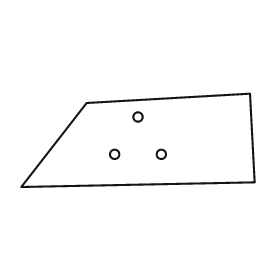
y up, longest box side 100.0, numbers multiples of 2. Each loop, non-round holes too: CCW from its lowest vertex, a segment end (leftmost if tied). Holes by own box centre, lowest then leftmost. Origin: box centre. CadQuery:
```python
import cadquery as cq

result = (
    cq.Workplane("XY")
    .moveTo(-50.0, -20.0)
    .lineTo(50.0, -18.0)
    .lineTo(48.0, 20.0)
    .lineTo(-22.0, 16.0)
    .close()
    .moveTo(-10.0, -6.0)
    .circle(2.0)
    .moveTo(10.0, -6.0)
    .circle(2.0)
    .moveTo(0.0, 10.0)
    .circle(2.0)
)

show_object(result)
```